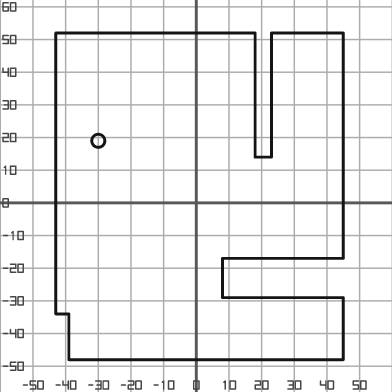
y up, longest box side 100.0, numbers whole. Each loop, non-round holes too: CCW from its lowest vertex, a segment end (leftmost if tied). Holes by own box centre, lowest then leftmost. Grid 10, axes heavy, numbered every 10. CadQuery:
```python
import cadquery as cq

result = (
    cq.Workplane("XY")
    .moveTo(-39.0, -48.0)
    .lineTo(45.0, -48.0)
    .lineTo(45.0, -29.0)
    .lineTo(8.0, -29.0)
    .lineTo(8.0, -17.0)
    .lineTo(45.0, -17.0)
    .lineTo(45.0, 52.0)
    .lineTo(23.0, 52.0)
    .lineTo(23.0, 14.0)
    .lineTo(18.0, 14.0)
    .lineTo(18.0, 52.0)
    .lineTo(-43.0, 52.0)
    .lineTo(-43.0, -34.0)
    .lineTo(-39.0, -34.0)
    .close()
    .moveTo(-30.0, 19.0)
    .circle(2.0)
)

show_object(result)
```